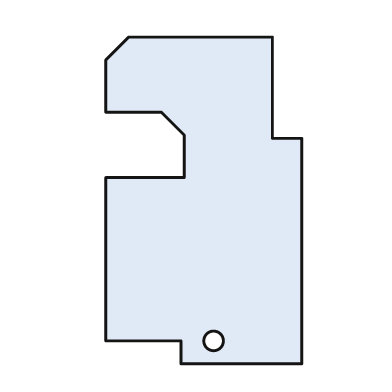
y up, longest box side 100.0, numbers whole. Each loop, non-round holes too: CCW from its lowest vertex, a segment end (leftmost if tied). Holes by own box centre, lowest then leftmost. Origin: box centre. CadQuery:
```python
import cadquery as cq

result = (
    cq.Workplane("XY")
    .moveTo(-7.0, -50.0)
    .lineTo(30.0, -50.0)
    .lineTo(30.0, 19.0)
    .lineTo(21.0, 19.0)
    .lineTo(21.0, 50.0)
    .lineTo(-23.0, 50.0)
    .lineTo(-30.0, 43.0)
    .lineTo(-30.0, 27.0)
    .lineTo(-13.0, 27.0)
    .lineTo(-6.0, 20.0)
    .lineTo(-6.0, 7.0)
    .lineTo(-30.0, 7.0)
    .lineTo(-30.0, -43.0)
    .lineTo(-7.0, -43.0)
    .close()
    .moveTo(3.0, -43.0)
    .circle(3.0)
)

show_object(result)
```